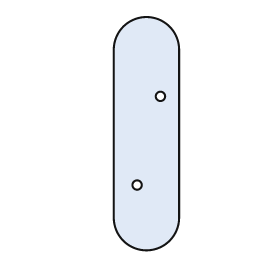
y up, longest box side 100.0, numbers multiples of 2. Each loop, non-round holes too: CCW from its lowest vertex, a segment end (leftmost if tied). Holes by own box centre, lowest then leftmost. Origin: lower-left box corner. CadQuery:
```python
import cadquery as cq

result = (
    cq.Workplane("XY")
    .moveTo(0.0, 14.0)
    .threePointArc((14.0, 0.0), (28.0, 14.0))
    .lineTo(28.0, 86.0)
    .threePointArc((14.0, 100.0), (0.0, 86.0))
    .close()
    .moveTo(10.0, 28.0)
    .circle(2.0)
    .moveTo(20.0, 66.0)
    .circle(2.0)
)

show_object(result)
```